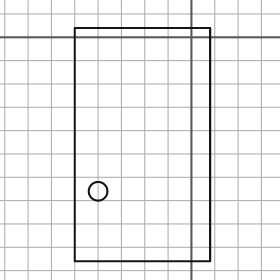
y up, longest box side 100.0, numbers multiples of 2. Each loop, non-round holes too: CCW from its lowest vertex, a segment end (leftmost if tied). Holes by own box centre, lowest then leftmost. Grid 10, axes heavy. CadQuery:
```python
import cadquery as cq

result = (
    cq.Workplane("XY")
    .moveTo(-50.0, -96.0)
    .lineTo(8.0, -96.0)
    .lineTo(8.0, 4.0)
    .lineTo(-50.0, 4.0)
    .close()
    .moveTo(-40.0, -66.0)
    .circle(4.0)
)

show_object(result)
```